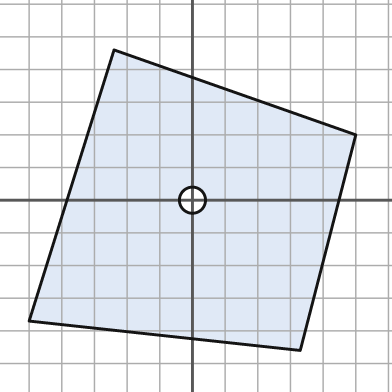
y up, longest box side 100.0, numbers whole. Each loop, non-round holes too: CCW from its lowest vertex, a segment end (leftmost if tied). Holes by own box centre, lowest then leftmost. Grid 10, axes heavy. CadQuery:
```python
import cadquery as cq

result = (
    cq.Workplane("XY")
    .moveTo(33.0, -46.0)
    .lineTo(50.0, 20.0)
    .lineTo(-24.0, 46.0)
    .lineTo(-50.0, -37.0)
    .close()
    .moveTo(0.0, 0.0)
    .circle(4.0)
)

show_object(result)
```